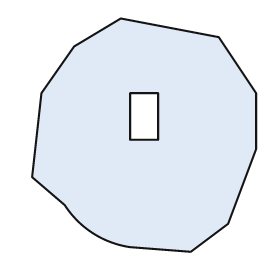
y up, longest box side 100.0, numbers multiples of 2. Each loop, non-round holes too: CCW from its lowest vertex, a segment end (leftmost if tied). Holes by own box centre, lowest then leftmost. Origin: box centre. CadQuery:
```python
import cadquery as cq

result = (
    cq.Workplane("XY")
    .moveTo(20.0, -50.0)
    .lineTo(36.0, -38.0)
    .lineTo(48.0, -6.0)
    .lineTo(48.0, 18.0)
    .lineTo(32.0, 42.0)
    .lineTo(-10.0, 50.0)
    .lineTo(-30.0, 38.0)
    .lineTo(-44.0, 18.0)
    .lineTo(-48.0, -18.0)
    .lineTo(-34.0, -30.0)
    .threePointArc((-22.0, -42.0), (-6.0, -48.0))
    .close()
    .moveTo(-6.0, -2.0)
    .lineTo(6.0, -2.0)
    .lineTo(6.0, 18.0)
    .lineTo(-6.0, 18.0)
    .close()
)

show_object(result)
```